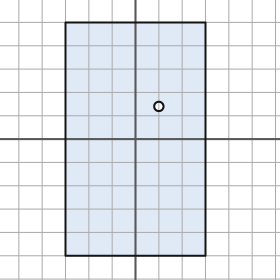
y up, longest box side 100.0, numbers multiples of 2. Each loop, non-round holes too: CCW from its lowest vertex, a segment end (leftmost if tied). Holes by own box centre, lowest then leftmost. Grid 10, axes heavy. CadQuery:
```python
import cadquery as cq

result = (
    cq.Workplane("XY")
    .moveTo(-30.0, -50.0)
    .lineTo(30.0, -50.0)
    .lineTo(30.0, 50.0)
    .lineTo(-30.0, 50.0)
    .close()
    .moveTo(10.0, 14.0)
    .circle(2.0)
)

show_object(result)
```